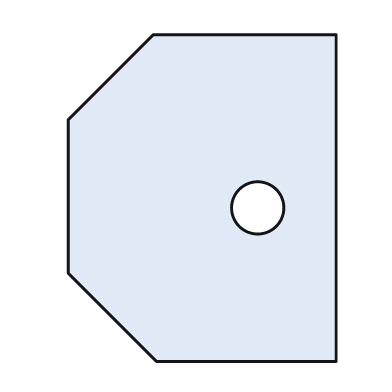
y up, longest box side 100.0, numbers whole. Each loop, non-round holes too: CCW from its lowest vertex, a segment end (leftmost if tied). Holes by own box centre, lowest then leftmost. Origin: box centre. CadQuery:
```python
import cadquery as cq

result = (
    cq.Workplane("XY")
    .moveTo(-14.0, -50.0)
    .lineTo(41.0, -50.0)
    .lineTo(41.0, 50.0)
    .lineTo(-15.0, 50.0)
    .lineTo(-41.0, 24.0)
    .lineTo(-41.0, -23.0)
    .close()
    .moveTo(17.0, -3.0)
    .circle(8.0)
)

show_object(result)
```